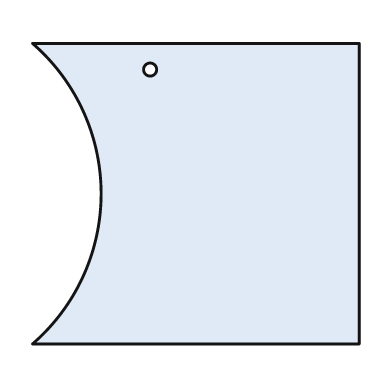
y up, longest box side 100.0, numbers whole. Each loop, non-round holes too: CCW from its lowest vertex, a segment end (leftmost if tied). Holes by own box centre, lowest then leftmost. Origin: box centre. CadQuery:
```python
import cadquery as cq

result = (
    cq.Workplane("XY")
    .moveTo(-50.0, -46.0)
    .lineTo(50.0, -46.0)
    .lineTo(50.0, 46.0)
    .lineTo(-50.0, 46.0)
    .threePointArc((-29.0, 0.0), (-50.0, -46.0))
    .close()
    .moveTo(-14.0, 38.0)
    .circle(2.0)
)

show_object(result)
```